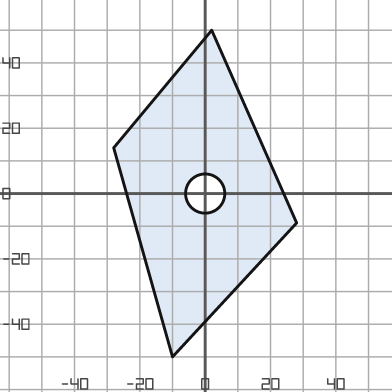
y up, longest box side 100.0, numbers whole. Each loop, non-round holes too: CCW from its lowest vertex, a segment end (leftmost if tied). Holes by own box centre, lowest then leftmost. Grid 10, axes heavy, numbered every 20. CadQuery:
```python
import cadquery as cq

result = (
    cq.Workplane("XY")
    .moveTo(-10.0, -50.0)
    .lineTo(28.0, -9.0)
    .lineTo(2.0, 50.0)
    .lineTo(-28.0, 14.0)
    .close()
    .moveTo(0.0, 0.0)
    .circle(6.0)
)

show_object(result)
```